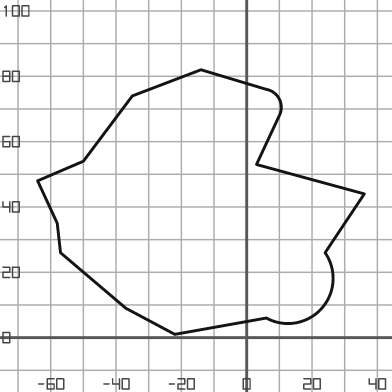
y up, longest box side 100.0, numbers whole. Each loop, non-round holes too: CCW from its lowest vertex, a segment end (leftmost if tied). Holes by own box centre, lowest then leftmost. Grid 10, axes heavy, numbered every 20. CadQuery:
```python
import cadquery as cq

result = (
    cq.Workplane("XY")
    .moveTo(-22.0, 1.0)
    .lineTo(6.0, 6.0)
    .threePointArc((23.0, 9.0), (24.0, 26.0))
    .lineTo(36.0, 44.0)
    .lineTo(3.0, 53.0)
    .lineTo(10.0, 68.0)
    .threePointArc((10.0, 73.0), (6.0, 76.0))
    .lineTo(-14.0, 82.0)
    .lineTo(-35.0, 74.0)
    .lineTo(-50.0, 54.0)
    .lineTo(-64.0, 48.0)
    .lineTo(-58.0, 35.0)
    .lineTo(-57.0, 26.0)
    .lineTo(-37.0, 9.0)
    .close()
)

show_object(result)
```